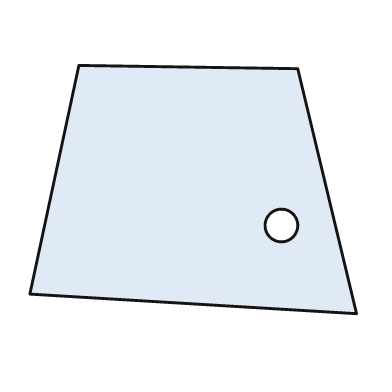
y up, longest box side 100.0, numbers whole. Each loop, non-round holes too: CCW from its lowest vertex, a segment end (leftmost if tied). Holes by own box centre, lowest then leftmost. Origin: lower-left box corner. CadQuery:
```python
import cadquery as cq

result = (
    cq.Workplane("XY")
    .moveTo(100.0, 0.0)
    .lineTo(82.0, 75.0)
    .lineTo(15.0, 76.0)
    .lineTo(0.0, 6.0)
    .close()
    .moveTo(77.0, 27.0)
    .circle(5.0)
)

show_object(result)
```